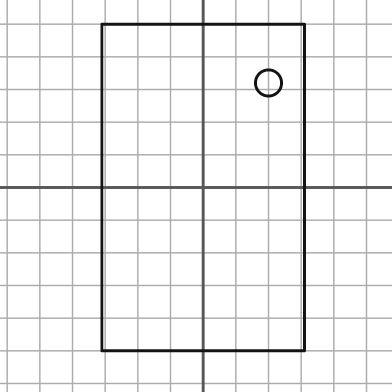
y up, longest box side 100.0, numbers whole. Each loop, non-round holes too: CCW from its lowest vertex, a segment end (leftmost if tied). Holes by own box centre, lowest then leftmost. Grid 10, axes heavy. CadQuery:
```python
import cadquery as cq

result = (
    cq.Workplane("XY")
    .moveTo(-31.0, -50.0)
    .lineTo(31.0, -50.0)
    .lineTo(31.0, 50.0)
    .lineTo(-31.0, 50.0)
    .close()
    .moveTo(20.0, 32.0)
    .circle(4.0)
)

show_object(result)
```